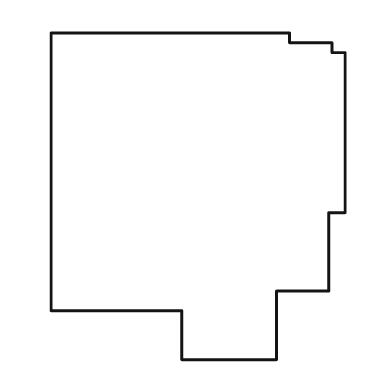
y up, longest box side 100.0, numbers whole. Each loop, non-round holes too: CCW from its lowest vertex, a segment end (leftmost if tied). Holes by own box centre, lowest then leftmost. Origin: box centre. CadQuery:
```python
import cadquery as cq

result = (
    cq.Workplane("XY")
    .moveTo(-5.0, -50.0)
    .lineTo(24.0, -50.0)
    .lineTo(24.0, -29.0)
    .lineTo(40.0, -29.0)
    .lineTo(40.0, -5.0)
    .lineTo(45.0, -5.0)
    .lineTo(45.0, 44.0)
    .lineTo(41.0, 44.0)
    .lineTo(41.0, 47.0)
    .lineTo(28.0, 47.0)
    .lineTo(28.0, 50.0)
    .lineTo(-45.0, 50.0)
    .lineTo(-45.0, -35.0)
    .lineTo(-5.0, -35.0)
    .close()
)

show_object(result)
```